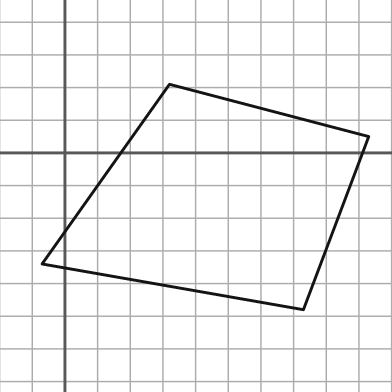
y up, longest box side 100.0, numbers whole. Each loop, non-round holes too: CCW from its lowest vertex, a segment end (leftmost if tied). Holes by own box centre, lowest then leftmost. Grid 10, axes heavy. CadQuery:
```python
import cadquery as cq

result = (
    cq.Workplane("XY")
    .moveTo(73.0, -48.0)
    .lineTo(93.0, 5.0)
    .lineTo(32.0, 21.0)
    .lineTo(-7.0, -34.0)
    .close()
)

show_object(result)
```